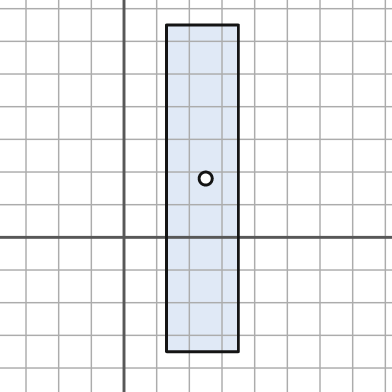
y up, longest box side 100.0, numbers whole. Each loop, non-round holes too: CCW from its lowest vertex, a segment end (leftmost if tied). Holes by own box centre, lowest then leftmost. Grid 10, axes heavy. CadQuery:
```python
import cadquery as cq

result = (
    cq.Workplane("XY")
    .moveTo(13.0, -35.0)
    .lineTo(35.0, -35.0)
    .lineTo(35.0, 65.0)
    .lineTo(13.0, 65.0)
    .close()
    .moveTo(25.0, 18.0)
    .circle(2.0)
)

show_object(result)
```